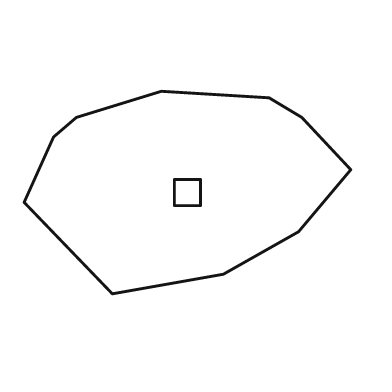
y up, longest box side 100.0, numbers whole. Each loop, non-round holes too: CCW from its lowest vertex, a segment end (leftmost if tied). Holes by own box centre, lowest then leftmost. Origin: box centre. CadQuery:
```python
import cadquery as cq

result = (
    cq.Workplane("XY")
    .moveTo(-23.0, -31.0)
    .lineTo(11.0, -25.0)
    .lineTo(34.0, -12.0)
    .lineTo(50.0, 7.0)
    .lineTo(35.0, 23.0)
    .lineTo(25.0, 29.0)
    .lineTo(-8.0, 31.0)
    .lineTo(-34.0, 23.0)
    .lineTo(-41.0, 17.0)
    .lineTo(-50.0, -3.0)
    .close()
    .moveTo(-4.0, -4.0)
    .lineTo(4.0, -4.0)
    .lineTo(4.0, 4.0)
    .lineTo(-4.0, 4.0)
    .close()
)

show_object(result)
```